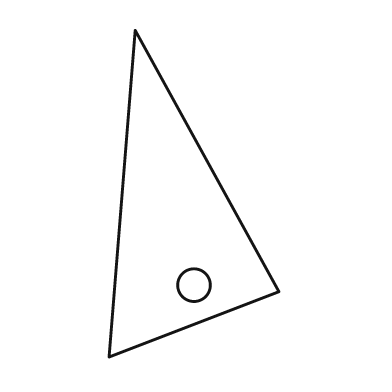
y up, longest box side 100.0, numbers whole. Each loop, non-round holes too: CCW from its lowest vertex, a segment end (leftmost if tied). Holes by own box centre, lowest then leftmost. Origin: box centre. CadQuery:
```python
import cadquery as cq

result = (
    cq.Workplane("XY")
    .moveTo(-26.0, -50.0)
    .lineTo(26.0, -30.0)
    .lineTo(-18.0, 50.0)
    .close()
    .moveTo(0.0, -28.0)
    .circle(5.0)
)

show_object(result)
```